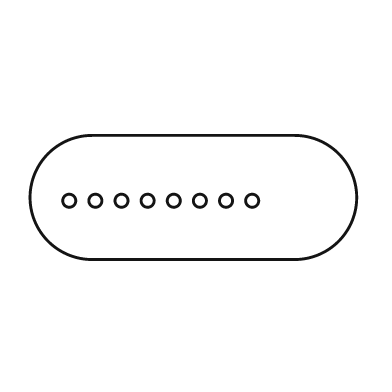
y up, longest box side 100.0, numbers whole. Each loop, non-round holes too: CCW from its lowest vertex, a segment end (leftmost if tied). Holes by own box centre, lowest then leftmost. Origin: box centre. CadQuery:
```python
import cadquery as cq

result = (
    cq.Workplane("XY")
    .moveTo(-31.0, -19.0)
    .lineTo(31.0, -19.0)
    .threePointArc((50.0, 0.0), (31.0, 19.0))
    .lineTo(-31.0, 19.0)
    .threePointArc((-50.0, 0.0), (-31.0, -19.0))
    .close()
    .moveTo(-38.0, -1.0)
    .circle(2.0)
    .moveTo(-30.0, -1.0)
    .circle(2.0)
    .moveTo(-22.0, -1.0)
    .circle(2.0)
    .moveTo(-14.0, -1.0)
    .circle(2.0)
    .moveTo(-6.0, -1.0)
    .circle(2.0)
    .moveTo(2.0, -1.0)
    .circle(2.0)
    .moveTo(10.0, -1.0)
    .circle(2.0)
    .moveTo(18.0, -1.0)
    .circle(2.0)
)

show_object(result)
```